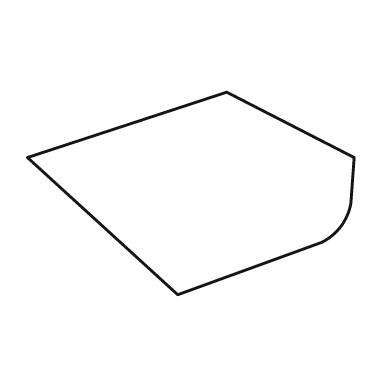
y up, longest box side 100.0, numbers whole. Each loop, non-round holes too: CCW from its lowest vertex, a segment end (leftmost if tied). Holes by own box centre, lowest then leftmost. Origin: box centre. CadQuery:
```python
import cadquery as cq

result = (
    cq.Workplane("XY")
    .moveTo(-4.0, -31.0)
    .lineTo(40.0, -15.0)
    .threePointArc((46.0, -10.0), (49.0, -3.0))
    .lineTo(50.0, 11.0)
    .lineTo(11.0, 31.0)
    .lineTo(-50.0, 11.0)
    .close()
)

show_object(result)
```